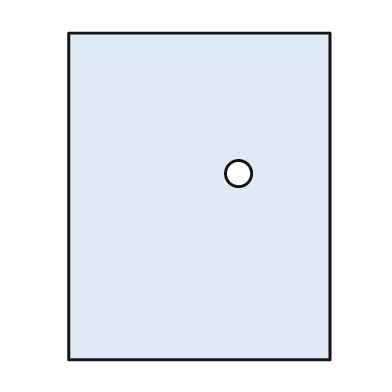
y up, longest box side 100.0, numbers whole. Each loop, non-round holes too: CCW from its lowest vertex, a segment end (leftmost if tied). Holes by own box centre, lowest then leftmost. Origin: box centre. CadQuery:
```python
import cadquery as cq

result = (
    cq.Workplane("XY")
    .moveTo(-40.0, -50.0)
    .lineTo(40.0, -50.0)
    .lineTo(40.0, 50.0)
    .lineTo(-40.0, 50.0)
    .close()
    .moveTo(12.0, 7.0)
    .circle(4.0)
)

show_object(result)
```